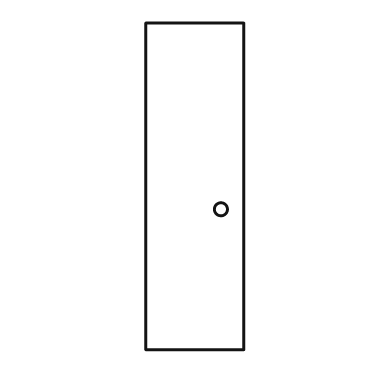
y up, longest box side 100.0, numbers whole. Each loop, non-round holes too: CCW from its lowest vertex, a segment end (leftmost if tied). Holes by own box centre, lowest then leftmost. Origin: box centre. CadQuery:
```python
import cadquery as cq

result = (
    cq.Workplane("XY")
    .moveTo(-15.0, -50.0)
    .lineTo(15.0, -50.0)
    .lineTo(15.0, 50.0)
    .lineTo(-15.0, 50.0)
    .close()
    .moveTo(8.0, -7.0)
    .circle(2.0)
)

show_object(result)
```